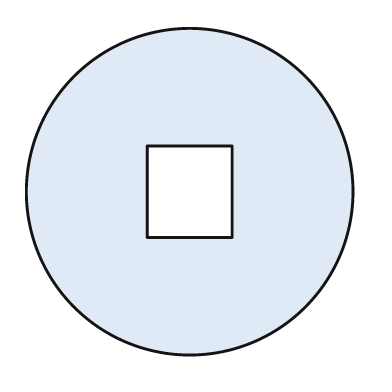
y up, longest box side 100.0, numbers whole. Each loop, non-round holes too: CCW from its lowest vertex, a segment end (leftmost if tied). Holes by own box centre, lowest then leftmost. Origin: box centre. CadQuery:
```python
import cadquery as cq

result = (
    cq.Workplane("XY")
    .moveTo(0.0, 0.0)
    .circle(50.0)
    .moveTo(-13.0, -14.0)
    .lineTo(13.0, -14.0)
    .lineTo(13.0, 14.0)
    .lineTo(-13.0, 14.0)
    .close()
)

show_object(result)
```